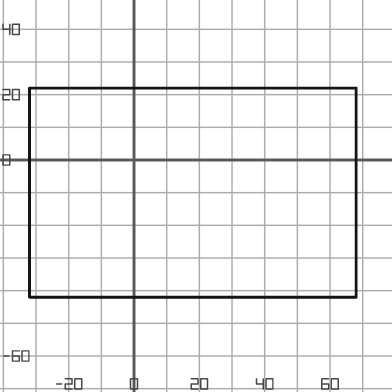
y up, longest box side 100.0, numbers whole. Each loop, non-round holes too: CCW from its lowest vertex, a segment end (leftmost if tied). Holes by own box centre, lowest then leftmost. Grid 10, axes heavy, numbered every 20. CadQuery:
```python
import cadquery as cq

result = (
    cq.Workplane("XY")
    .moveTo(-32.0, -42.0)
    .lineTo(68.0, -42.0)
    .lineTo(68.0, 22.0)
    .lineTo(-32.0, 22.0)
    .close()
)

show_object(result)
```